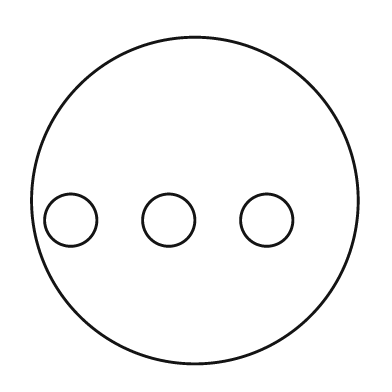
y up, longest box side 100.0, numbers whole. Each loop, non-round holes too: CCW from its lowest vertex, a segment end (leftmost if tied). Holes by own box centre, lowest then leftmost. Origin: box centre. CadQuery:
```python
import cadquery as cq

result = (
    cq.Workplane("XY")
    .moveTo(0.0, 0.0)
    .circle(50.0)
    .moveTo(-38.0, -6.0)
    .circle(8.0)
    .moveTo(-8.0, -6.0)
    .circle(8.0)
    .moveTo(22.0, -6.0)
    .circle(8.0)
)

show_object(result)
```